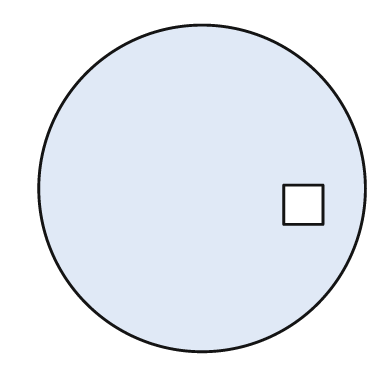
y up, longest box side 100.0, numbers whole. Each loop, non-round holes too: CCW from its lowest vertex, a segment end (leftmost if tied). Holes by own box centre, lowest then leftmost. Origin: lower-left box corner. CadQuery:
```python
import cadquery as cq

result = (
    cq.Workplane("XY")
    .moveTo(50.0, 50.0)
    .circle(50.0)
    .moveTo(75.0, 39.0)
    .lineTo(87.0, 39.0)
    .lineTo(87.0, 51.0)
    .lineTo(75.0, 51.0)
    .close()
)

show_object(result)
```